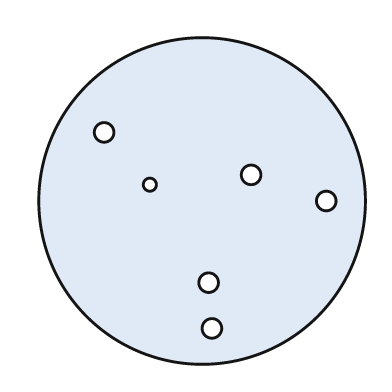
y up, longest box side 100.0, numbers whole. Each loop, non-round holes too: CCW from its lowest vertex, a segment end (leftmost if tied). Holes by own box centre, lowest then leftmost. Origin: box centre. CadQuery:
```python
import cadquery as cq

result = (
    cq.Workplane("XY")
    .moveTo(0.0, 0.0)
    .circle(50.0)
    .moveTo(3.0, -39.0)
    .circle(3.0)
    .moveTo(2.0, -25.0)
    .circle(3.0)
    .moveTo(38.0, 0.0)
    .circle(3.0)
    .moveTo(-16.0, 5.0)
    .circle(2.0)
    .moveTo(15.0, 8.0)
    .circle(3.0)
    .moveTo(-30.0, 21.0)
    .circle(3.0)
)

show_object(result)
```